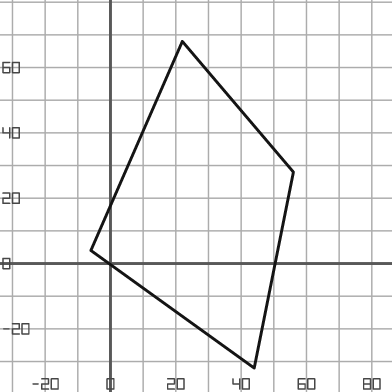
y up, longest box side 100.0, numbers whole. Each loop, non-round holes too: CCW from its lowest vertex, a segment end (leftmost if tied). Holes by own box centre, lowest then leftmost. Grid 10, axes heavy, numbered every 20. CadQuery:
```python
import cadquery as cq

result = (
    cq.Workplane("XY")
    .moveTo(44.0, -32.0)
    .lineTo(56.0, 28.0)
    .lineTo(22.0, 68.0)
    .lineTo(-6.0, 4.0)
    .close()
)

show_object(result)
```